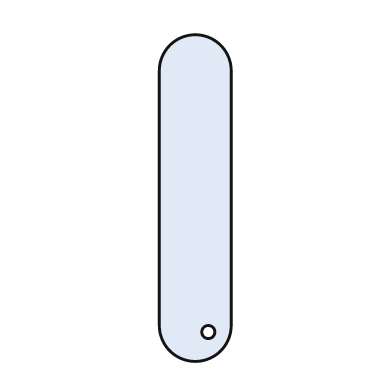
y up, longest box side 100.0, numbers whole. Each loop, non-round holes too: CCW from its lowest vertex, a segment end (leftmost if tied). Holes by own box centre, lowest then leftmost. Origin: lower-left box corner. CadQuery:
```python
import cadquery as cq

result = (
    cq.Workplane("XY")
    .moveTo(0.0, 11.0)
    .threePointArc((11.0, 0.0), (22.0, 11.0))
    .lineTo(22.0, 89.0)
    .threePointArc((11.0, 100.0), (0.0, 89.0))
    .close()
    .moveTo(15.0, 9.0)
    .circle(2.0)
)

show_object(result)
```